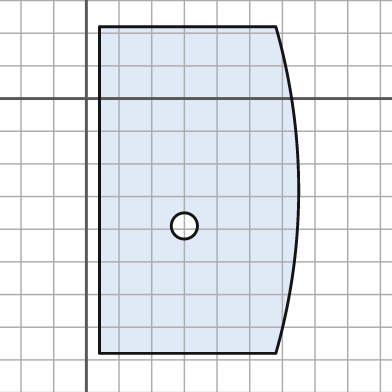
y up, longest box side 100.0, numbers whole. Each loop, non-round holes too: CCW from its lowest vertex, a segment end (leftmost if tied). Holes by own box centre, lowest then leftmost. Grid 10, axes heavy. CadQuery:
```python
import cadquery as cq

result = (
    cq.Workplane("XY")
    .moveTo(4.0, -78.0)
    .lineTo(58.0, -78.0)
    .threePointArc((65.0, -28.0), (58.0, 22.0))
    .lineTo(4.0, 22.0)
    .close()
    .moveTo(30.0, -39.0)
    .circle(4.0)
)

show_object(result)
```